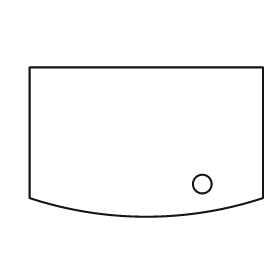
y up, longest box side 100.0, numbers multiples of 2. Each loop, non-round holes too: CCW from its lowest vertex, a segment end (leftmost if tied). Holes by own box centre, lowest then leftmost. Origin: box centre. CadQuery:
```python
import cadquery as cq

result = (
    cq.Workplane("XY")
    .moveTo(-50.0, -24.0)
    .threePointArc((0.0, -32.0), (50.0, -24.0))
    .lineTo(50.0, 32.0)
    .lineTo(-50.0, 32.0)
    .close()
    .moveTo(24.0, -18.0)
    .circle(4.0)
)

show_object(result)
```